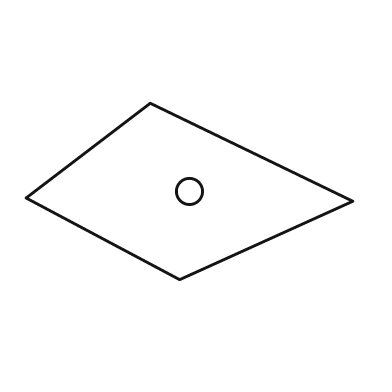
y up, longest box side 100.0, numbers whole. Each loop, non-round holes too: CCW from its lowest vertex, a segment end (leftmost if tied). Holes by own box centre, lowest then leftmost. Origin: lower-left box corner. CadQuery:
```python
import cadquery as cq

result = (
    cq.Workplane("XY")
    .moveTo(47.0, 0.0)
    .lineTo(100.0, 24.0)
    .lineTo(38.0, 54.0)
    .lineTo(0.0, 25.0)
    .close()
    .moveTo(50.0, 27.0)
    .circle(4.0)
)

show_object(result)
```